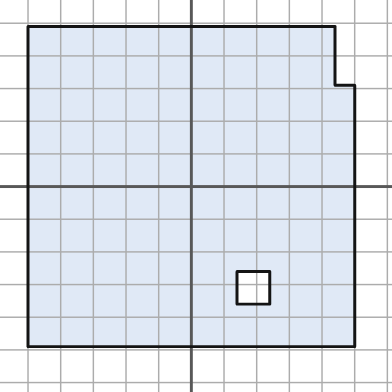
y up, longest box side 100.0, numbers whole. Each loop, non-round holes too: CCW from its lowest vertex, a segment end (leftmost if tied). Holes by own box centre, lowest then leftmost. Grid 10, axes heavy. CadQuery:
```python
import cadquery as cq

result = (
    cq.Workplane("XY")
    .moveTo(-50.0, -49.0)
    .lineTo(50.0, -49.0)
    .lineTo(50.0, 31.0)
    .lineTo(44.0, 31.0)
    .lineTo(44.0, 49.0)
    .lineTo(-50.0, 49.0)
    .close()
    .moveTo(14.0, -36.0)
    .lineTo(24.0, -36.0)
    .lineTo(24.0, -26.0)
    .lineTo(14.0, -26.0)
    .close()
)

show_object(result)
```